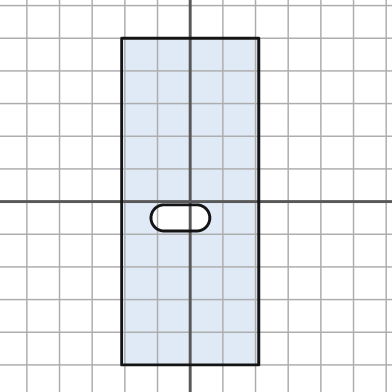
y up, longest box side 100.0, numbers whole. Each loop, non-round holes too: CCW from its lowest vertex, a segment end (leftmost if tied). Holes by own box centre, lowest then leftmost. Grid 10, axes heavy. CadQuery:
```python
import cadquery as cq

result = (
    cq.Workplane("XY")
    .moveTo(-21.0, -50.0)
    .lineTo(21.0, -50.0)
    .lineTo(21.0, 50.0)
    .lineTo(-21.0, 50.0)
    .close()
    .moveTo(-8.0, -9.0)
    .lineTo(2.0, -9.0)
    .threePointArc((6.0, -5.0), (2.0, -1.0))
    .lineTo(-8.0, -1.0)
    .threePointArc((-12.0, -5.0), (-8.0, -9.0))
    .close()
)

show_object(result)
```